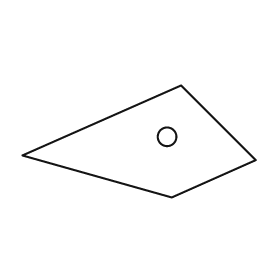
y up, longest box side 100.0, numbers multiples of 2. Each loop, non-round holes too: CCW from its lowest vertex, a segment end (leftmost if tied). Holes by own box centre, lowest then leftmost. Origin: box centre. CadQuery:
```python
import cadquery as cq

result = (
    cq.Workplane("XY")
    .moveTo(14.0, -24.0)
    .lineTo(50.0, -8.0)
    .lineTo(18.0, 24.0)
    .lineTo(-50.0, -6.0)
    .close()
    .moveTo(12.0, 2.0)
    .circle(4.0)
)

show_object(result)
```